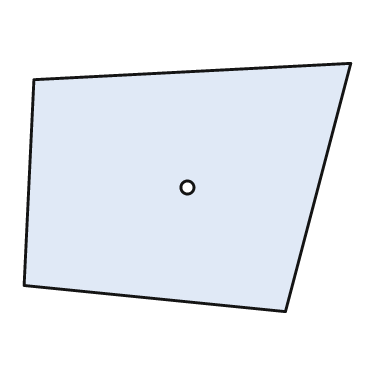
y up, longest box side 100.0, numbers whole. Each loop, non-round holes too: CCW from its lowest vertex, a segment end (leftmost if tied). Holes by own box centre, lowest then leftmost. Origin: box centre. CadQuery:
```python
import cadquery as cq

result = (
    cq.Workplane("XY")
    .moveTo(30.0, -38.0)
    .lineTo(50.0, 38.0)
    .lineTo(-47.0, 33.0)
    .lineTo(-50.0, -30.0)
    .close()
    .moveTo(0.0, 0.0)
    .circle(2.0)
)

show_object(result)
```